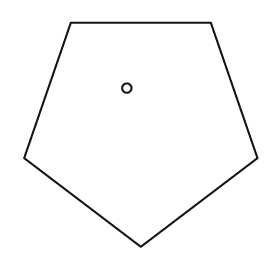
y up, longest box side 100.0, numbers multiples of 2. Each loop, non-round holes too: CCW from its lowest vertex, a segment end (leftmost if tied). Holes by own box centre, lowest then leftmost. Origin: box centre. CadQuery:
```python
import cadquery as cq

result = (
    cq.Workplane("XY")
    .moveTo(0.0, -48.0)
    .lineTo(50.0, -10.0)
    .lineTo(30.0, 48.0)
    .lineTo(-30.0, 48.0)
    .lineTo(-50.0, -10.0)
    .close()
    .moveTo(-6.0, 20.0)
    .circle(2.0)
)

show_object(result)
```